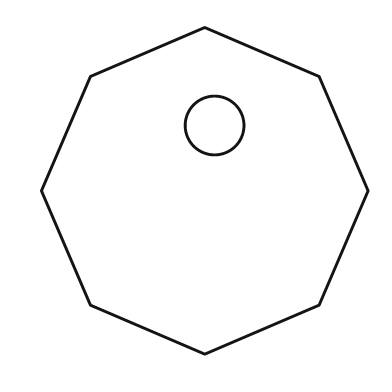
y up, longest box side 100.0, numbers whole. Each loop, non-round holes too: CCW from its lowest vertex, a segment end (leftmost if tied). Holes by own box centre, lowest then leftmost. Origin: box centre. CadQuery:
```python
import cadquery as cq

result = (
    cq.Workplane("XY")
    .moveTo(0.0, -50.0)
    .lineTo(35.0, -35.0)
    .lineTo(50.0, 0.0)
    .lineTo(35.0, 35.0)
    .lineTo(0.0, 50.0)
    .lineTo(-35.0, 35.0)
    .lineTo(-50.0, 0.0)
    .lineTo(-35.0, -35.0)
    .close()
    .moveTo(3.0, 20.0)
    .circle(9.0)
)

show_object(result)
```